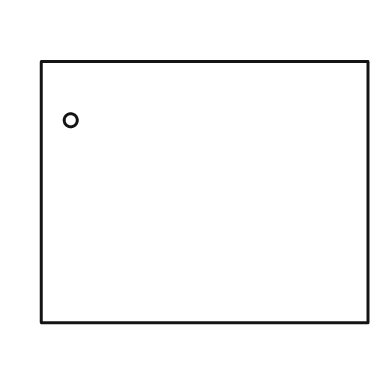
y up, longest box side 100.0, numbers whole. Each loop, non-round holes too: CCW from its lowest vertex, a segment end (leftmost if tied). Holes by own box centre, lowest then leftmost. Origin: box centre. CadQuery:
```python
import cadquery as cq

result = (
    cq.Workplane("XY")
    .moveTo(-50.0, -40.0)
    .lineTo(50.0, -40.0)
    .lineTo(50.0, 40.0)
    .lineTo(-50.0, 40.0)
    .close()
    .moveTo(-41.0, 22.0)
    .circle(2.0)
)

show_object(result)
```